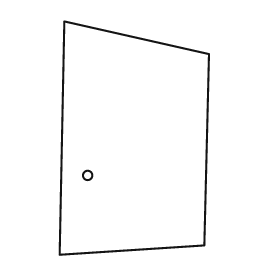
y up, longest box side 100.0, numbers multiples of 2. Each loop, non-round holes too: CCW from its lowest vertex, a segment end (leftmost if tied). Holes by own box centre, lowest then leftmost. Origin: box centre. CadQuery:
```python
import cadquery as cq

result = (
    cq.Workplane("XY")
    .moveTo(-32.0, -50.0)
    .lineTo(30.0, -46.0)
    .lineTo(32.0, 36.0)
    .lineTo(-30.0, 50.0)
    .close()
    .moveTo(-20.0, -16.0)
    .circle(2.0)
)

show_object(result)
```